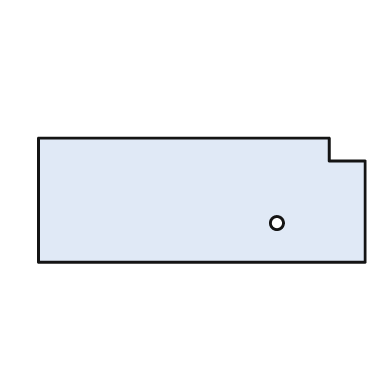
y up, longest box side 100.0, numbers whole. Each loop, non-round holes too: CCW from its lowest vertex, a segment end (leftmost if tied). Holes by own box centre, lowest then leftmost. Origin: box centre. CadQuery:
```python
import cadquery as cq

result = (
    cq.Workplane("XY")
    .moveTo(-50.0, -19.0)
    .lineTo(50.0, -19.0)
    .lineTo(50.0, 12.0)
    .lineTo(39.0, 12.0)
    .lineTo(39.0, 19.0)
    .lineTo(-50.0, 19.0)
    .close()
    .moveTo(23.0, -7.0)
    .circle(2.0)
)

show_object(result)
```